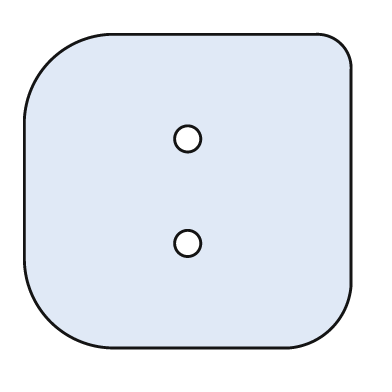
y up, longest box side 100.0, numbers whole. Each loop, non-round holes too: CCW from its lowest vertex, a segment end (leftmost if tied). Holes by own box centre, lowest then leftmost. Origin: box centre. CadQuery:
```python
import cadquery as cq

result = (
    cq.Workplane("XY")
    .moveTo(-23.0, -48.0)
    .lineTo(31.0, -48.0)
    .threePointArc((44.0, -42.0), (50.0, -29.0))
    .lineTo(50.0, 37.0)
    .threePointArc((47.0, 45.0), (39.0, 48.0))
    .lineTo(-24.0, 48.0)
    .threePointArc((-42.0, 40.0), (-50.0, 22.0))
    .lineTo(-50.0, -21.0)
    .threePointArc((-42.0, -40.0), (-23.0, -48.0))
    .close()
    .moveTo(0.0, -16.0)
    .circle(4.0)
    .moveTo(0.0, 16.0)
    .circle(4.0)
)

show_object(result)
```